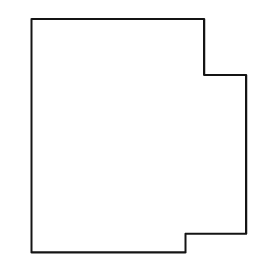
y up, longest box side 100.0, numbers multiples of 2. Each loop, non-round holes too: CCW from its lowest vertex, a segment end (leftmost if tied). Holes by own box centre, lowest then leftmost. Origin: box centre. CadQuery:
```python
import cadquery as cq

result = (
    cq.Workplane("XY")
    .moveTo(-46.0, -50.0)
    .lineTo(20.0, -50.0)
    .lineTo(20.0, -42.0)
    .lineTo(46.0, -42.0)
    .lineTo(46.0, 26.0)
    .lineTo(28.0, 26.0)
    .lineTo(28.0, 50.0)
    .lineTo(-46.0, 50.0)
    .close()
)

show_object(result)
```